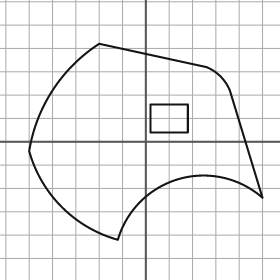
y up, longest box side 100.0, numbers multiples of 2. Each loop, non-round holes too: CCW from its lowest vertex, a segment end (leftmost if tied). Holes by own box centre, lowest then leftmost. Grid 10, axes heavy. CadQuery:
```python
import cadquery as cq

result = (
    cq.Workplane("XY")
    .moveTo(-12.0, -42.0)
    .threePointArc((14.0, -16.0), (50.0, -24.0))
    .lineTo(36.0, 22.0)
    .threePointArc((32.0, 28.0), (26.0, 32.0))
    .lineTo(-20.0, 42.0)
    .threePointArc((-40.0, 22.0), (-50.0, -4.0))
    .threePointArc((-36.0, -28.0), (-12.0, -42.0))
    .close()
    .moveTo(2.0, 4.0)
    .lineTo(18.0, 4.0)
    .lineTo(18.0, 16.0)
    .lineTo(2.0, 16.0)
    .close()
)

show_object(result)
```